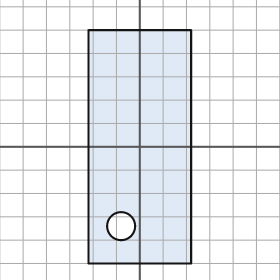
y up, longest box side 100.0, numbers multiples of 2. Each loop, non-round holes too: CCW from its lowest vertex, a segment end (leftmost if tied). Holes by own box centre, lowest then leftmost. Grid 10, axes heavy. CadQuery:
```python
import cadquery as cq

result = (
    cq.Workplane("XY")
    .moveTo(-22.0, -50.0)
    .lineTo(22.0, -50.0)
    .lineTo(22.0, 50.0)
    .lineTo(-22.0, 50.0)
    .close()
    .moveTo(-8.0, -34.0)
    .circle(6.0)
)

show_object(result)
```